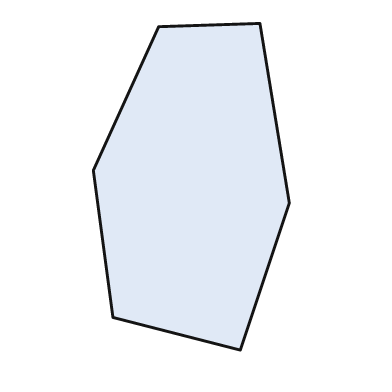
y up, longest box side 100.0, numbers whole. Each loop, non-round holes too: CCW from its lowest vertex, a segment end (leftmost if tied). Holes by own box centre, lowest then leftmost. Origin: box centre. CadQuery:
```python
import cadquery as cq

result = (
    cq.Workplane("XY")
    .moveTo(15.0, -50.0)
    .lineTo(30.0, -5.0)
    .lineTo(21.0, 50.0)
    .lineTo(-10.0, 49.0)
    .lineTo(-30.0, 5.0)
    .lineTo(-24.0, -40.0)
    .close()
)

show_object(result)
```